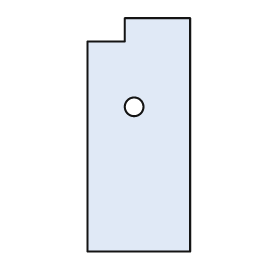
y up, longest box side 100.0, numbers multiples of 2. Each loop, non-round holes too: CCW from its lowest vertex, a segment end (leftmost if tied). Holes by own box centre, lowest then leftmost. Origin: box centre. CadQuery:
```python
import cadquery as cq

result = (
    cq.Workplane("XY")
    .moveTo(-22.0, -50.0)
    .lineTo(22.0, -50.0)
    .lineTo(22.0, 50.0)
    .lineTo(-6.0, 50.0)
    .lineTo(-6.0, 40.0)
    .lineTo(-22.0, 40.0)
    .close()
    .moveTo(-2.0, 12.0)
    .circle(4.0)
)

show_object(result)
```